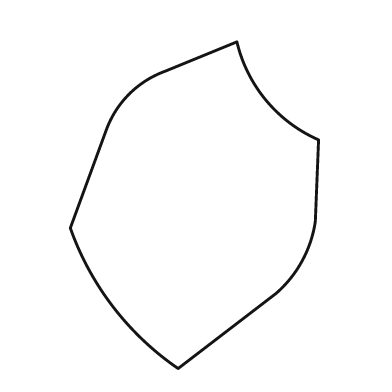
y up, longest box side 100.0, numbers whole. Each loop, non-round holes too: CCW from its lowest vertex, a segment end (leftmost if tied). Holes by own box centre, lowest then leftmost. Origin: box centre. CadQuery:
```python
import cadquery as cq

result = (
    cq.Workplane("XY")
    .moveTo(-5.0, -50.0)
    .lineTo(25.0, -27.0)
    .threePointArc((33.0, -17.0), (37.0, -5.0))
    .lineTo(38.0, 20.0)
    .threePointArc((22.0, 32.0), (13.0, 50.0))
    .lineTo(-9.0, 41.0)
    .threePointArc((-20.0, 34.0), (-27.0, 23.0))
    .lineTo(-38.0, -7.0)
    .threePointArc((-25.0, -31.0), (-5.0, -50.0))
    .close()
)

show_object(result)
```